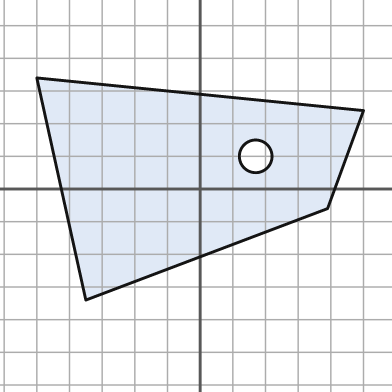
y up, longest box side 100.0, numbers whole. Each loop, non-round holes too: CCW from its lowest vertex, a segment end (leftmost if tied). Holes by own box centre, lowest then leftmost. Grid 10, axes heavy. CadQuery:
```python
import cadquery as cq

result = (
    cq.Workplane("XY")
    .moveTo(-35.0, -34.0)
    .lineTo(39.0, -6.0)
    .lineTo(50.0, 24.0)
    .lineTo(-50.0, 34.0)
    .close()
    .moveTo(17.0, 10.0)
    .circle(5.0)
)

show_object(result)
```